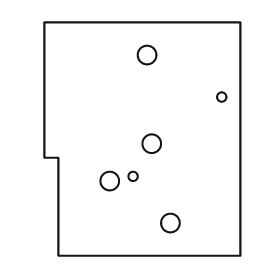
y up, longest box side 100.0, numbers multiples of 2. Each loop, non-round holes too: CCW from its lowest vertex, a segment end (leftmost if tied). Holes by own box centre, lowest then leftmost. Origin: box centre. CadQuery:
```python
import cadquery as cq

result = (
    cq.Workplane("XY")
    .moveTo(-36.0, -50.0)
    .lineTo(42.0, -50.0)
    .lineTo(42.0, 50.0)
    .lineTo(-42.0, 50.0)
    .lineTo(-42.0, -8.0)
    .lineTo(-36.0, -8.0)
    .close()
    .moveTo(12.0, -36.0)
    .circle(4.0)
    .moveTo(-14.0, -18.0)
    .circle(4.0)
    .moveTo(-4.0, -16.0)
    .circle(2.0)
    .moveTo(4.0, -2.0)
    .circle(4.0)
    .moveTo(34.0, 18.0)
    .circle(2.0)
    .moveTo(2.0, 36.0)
    .circle(4.0)
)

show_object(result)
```